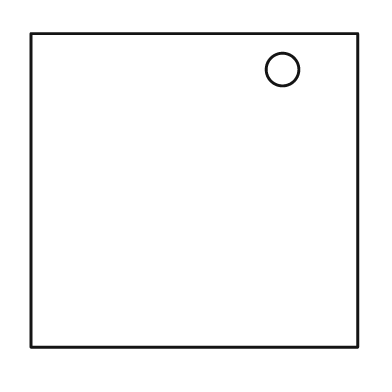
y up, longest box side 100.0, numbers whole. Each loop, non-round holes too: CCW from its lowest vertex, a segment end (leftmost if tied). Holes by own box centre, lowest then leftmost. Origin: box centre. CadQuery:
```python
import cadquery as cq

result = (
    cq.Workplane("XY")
    .moveTo(-50.0, -48.0)
    .lineTo(50.0, -48.0)
    .lineTo(50.0, 48.0)
    .lineTo(-50.0, 48.0)
    .close()
    .moveTo(27.0, 37.0)
    .circle(5.0)
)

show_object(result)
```